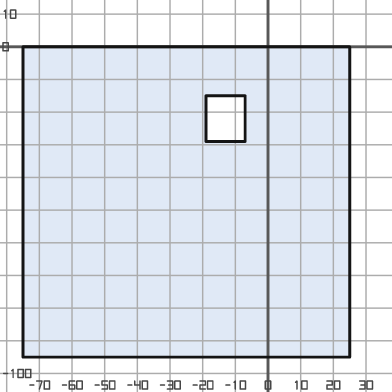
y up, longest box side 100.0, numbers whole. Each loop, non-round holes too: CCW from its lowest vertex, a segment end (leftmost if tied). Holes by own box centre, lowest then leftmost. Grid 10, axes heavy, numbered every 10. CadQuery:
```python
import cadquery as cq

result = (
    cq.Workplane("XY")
    .moveTo(-75.0, -95.0)
    .lineTo(25.0, -95.0)
    .lineTo(25.0, 0.0)
    .lineTo(-75.0, 0.0)
    .close()
    .moveTo(-19.0, -29.0)
    .lineTo(-7.0, -29.0)
    .lineTo(-7.0, -15.0)
    .lineTo(-19.0, -15.0)
    .close()
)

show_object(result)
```